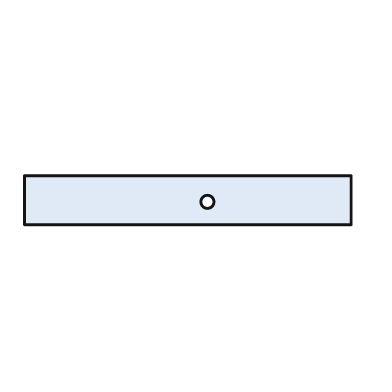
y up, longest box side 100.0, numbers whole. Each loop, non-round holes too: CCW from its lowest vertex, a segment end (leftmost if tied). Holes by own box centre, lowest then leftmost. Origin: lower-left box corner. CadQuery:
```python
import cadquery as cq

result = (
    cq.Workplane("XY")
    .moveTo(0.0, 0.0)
    .lineTo(100.0, 0.0)
    .lineTo(100.0, 15.0)
    .lineTo(0.0, 15.0)
    .close()
    .moveTo(56.0, 7.0)
    .circle(2.0)
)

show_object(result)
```